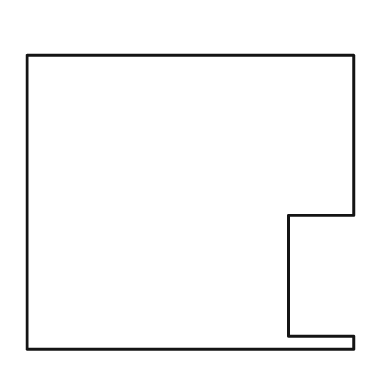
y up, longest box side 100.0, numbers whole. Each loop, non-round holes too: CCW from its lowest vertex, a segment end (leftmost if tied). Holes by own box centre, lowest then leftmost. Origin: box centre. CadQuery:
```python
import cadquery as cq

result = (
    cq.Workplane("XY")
    .moveTo(-50.0, -45.0)
    .lineTo(50.0, -45.0)
    .lineTo(50.0, -41.0)
    .lineTo(30.0, -41.0)
    .lineTo(30.0, -4.0)
    .lineTo(50.0, -4.0)
    .lineTo(50.0, 45.0)
    .lineTo(-50.0, 45.0)
    .close()
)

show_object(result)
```